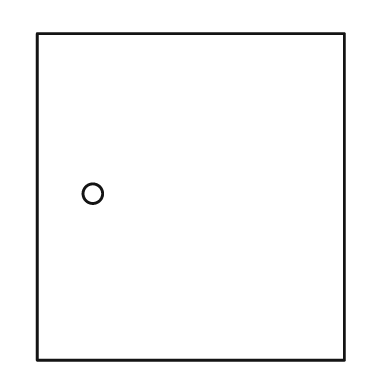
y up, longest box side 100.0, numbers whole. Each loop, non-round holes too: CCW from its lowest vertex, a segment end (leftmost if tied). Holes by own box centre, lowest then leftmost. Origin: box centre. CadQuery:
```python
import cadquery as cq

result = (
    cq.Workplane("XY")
    .moveTo(-47.0, -50.0)
    .lineTo(47.0, -50.0)
    .lineTo(47.0, 50.0)
    .lineTo(-47.0, 50.0)
    .close()
    .moveTo(-30.0, 1.0)
    .circle(3.0)
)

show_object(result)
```